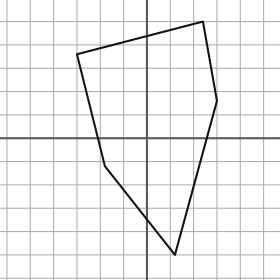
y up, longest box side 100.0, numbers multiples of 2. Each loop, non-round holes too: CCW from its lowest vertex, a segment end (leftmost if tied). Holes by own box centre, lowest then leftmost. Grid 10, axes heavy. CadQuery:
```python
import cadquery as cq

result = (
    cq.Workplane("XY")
    .moveTo(12.0, -50.0)
    .lineTo(30.0, 16.0)
    .lineTo(24.0, 50.0)
    .lineTo(-30.0, 36.0)
    .lineTo(-18.0, -12.0)
    .close()
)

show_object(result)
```